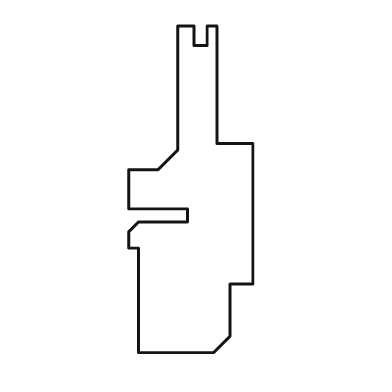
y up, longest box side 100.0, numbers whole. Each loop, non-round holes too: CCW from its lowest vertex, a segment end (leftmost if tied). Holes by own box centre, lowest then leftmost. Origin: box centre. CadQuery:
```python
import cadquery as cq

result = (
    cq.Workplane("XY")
    .moveTo(-16.0, -50.0)
    .lineTo(7.0, -50.0)
    .lineTo(12.0, -45.0)
    .lineTo(12.0, -29.0)
    .lineTo(19.0, -29.0)
    .lineTo(19.0, 14.0)
    .lineTo(8.0, 14.0)
    .lineTo(8.0, 50.0)
    .lineTo(5.0, 50.0)
    .lineTo(5.0, 44.0)
    .lineTo(1.0, 44.0)
    .lineTo(1.0, 50.0)
    .lineTo(-4.0, 50.0)
    .lineTo(-4.0, 12.0)
    .lineTo(-10.0, 6.0)
    .lineTo(-19.0, 6.0)
    .lineTo(-19.0, -6.0)
    .lineTo(-1.0, -6.0)
    .lineTo(-1.0, -10.0)
    .lineTo(-16.0, -10.0)
    .lineTo(-19.0, -13.0)
    .lineTo(-19.0, -18.0)
    .lineTo(-16.0, -18.0)
    .close()
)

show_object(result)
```